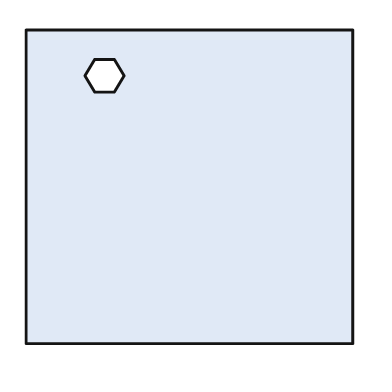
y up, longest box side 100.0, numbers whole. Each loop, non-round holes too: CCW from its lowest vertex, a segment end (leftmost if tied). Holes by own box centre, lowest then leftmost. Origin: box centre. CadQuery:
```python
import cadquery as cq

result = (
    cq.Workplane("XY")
    .moveTo(-50.0, -48.0)
    .lineTo(50.0, -48.0)
    .lineTo(50.0, 48.0)
    .lineTo(-50.0, 48.0)
    .close()
    .moveTo(-29.0, 29.0)
    .lineTo(-23.0, 29.0)
    .lineTo(-20.0, 34.0)
    .lineTo(-23.0, 39.0)
    .lineTo(-29.0, 39.0)
    .lineTo(-32.0, 34.0)
    .close()
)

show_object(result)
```